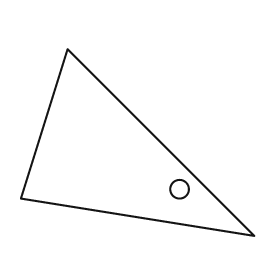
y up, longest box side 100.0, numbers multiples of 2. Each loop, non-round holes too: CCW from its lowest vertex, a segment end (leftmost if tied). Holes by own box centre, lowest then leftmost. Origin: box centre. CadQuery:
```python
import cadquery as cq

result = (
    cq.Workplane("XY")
    .moveTo(50.0, -40.0)
    .lineTo(-30.0, 40.0)
    .lineTo(-50.0, -24.0)
    .close()
    .moveTo(18.0, -20.0)
    .circle(4.0)
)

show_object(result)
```